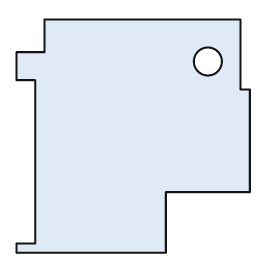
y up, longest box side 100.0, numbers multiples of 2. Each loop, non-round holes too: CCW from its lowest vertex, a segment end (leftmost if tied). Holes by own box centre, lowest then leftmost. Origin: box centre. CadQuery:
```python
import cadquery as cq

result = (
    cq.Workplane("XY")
    .moveTo(-50.0, -50.0)
    .lineTo(14.0, -50.0)
    .lineTo(14.0, -24.0)
    .lineTo(50.0, -24.0)
    .lineTo(50.0, 20.0)
    .lineTo(46.0, 20.0)
    .lineTo(46.0, 50.0)
    .lineTo(-38.0, 50.0)
    .lineTo(-38.0, 36.0)
    .lineTo(-50.0, 36.0)
    .lineTo(-50.0, 24.0)
    .lineTo(-42.0, 24.0)
    .lineTo(-42.0, -46.0)
    .lineTo(-50.0, -46.0)
    .close()
    .moveTo(32.0, 32.0)
    .circle(6.0)
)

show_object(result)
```